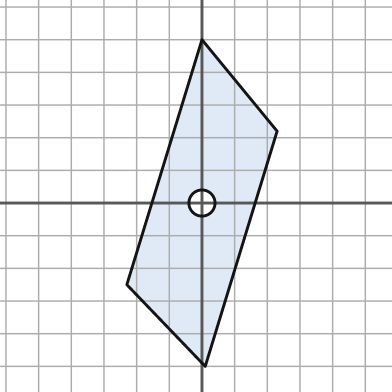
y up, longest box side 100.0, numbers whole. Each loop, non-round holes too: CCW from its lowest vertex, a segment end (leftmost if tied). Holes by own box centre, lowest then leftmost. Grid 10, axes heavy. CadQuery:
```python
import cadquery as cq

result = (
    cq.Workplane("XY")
    .moveTo(1.0, -50.0)
    .lineTo(23.0, 22.0)
    .lineTo(0.0, 50.0)
    .lineTo(-23.0, -25.0)
    .close()
    .moveTo(0.0, 0.0)
    .circle(4.0)
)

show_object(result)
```